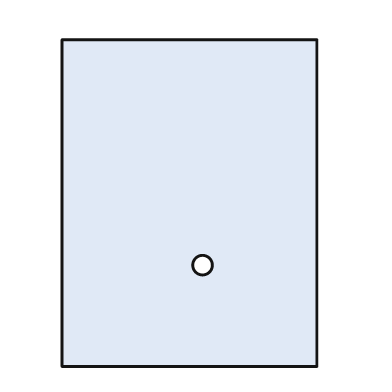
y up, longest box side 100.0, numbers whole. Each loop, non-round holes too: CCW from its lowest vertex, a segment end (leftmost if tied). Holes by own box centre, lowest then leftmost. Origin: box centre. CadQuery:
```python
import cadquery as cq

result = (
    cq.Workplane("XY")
    .moveTo(-39.0, -50.0)
    .lineTo(39.0, -50.0)
    .lineTo(39.0, 50.0)
    .lineTo(-39.0, 50.0)
    .close()
    .moveTo(4.0, -19.0)
    .circle(3.0)
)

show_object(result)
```